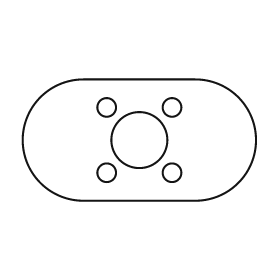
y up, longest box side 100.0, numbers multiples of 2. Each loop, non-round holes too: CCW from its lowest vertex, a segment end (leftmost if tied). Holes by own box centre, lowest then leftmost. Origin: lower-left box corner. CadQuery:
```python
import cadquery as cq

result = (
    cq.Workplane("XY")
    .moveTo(26.0, 0.0)
    .lineTo(74.0, 0.0)
    .threePointArc((100.0, 26.0), (74.0, 52.0))
    .lineTo(26.0, 52.0)
    .threePointArc((0.0, 26.0), (26.0, 0.0))
    .close()
    .moveTo(36.0, 12.0)
    .circle(4.0)
    .moveTo(64.0, 12.0)
    .circle(4.0)
    .moveTo(50.0, 26.0)
    .circle(12.0)
    .moveTo(36.0, 40.0)
    .circle(4.0)
    .moveTo(64.0, 40.0)
    .circle(4.0)
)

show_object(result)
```